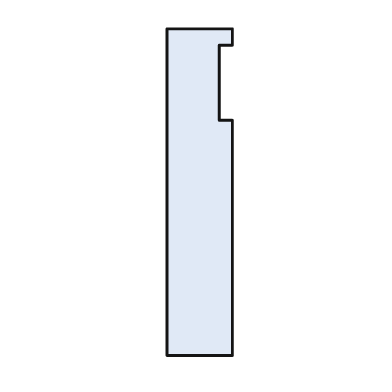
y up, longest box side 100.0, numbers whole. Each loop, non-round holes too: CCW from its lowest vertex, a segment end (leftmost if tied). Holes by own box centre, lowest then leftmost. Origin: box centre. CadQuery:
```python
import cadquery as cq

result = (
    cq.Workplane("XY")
    .moveTo(-10.0, -50.0)
    .lineTo(10.0, -50.0)
    .lineTo(10.0, 22.0)
    .lineTo(6.0, 22.0)
    .lineTo(6.0, 45.0)
    .lineTo(10.0, 45.0)
    .lineTo(10.0, 50.0)
    .lineTo(-10.0, 50.0)
    .close()
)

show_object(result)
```